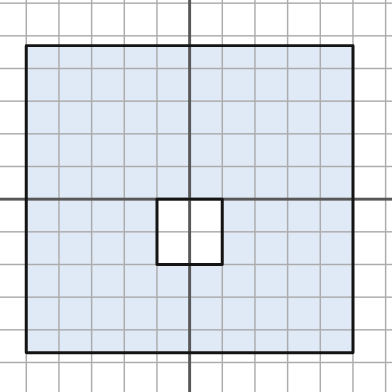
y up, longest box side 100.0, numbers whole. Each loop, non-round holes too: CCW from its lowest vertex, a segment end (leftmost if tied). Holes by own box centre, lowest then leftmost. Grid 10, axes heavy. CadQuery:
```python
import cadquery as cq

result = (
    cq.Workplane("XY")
    .moveTo(-50.0, -47.0)
    .lineTo(50.0, -47.0)
    .lineTo(50.0, 47.0)
    .lineTo(-50.0, 47.0)
    .close()
    .moveTo(-10.0, -20.0)
    .lineTo(10.0, -20.0)
    .lineTo(10.0, 0.0)
    .lineTo(-10.0, 0.0)
    .close()
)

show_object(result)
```